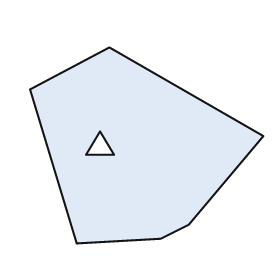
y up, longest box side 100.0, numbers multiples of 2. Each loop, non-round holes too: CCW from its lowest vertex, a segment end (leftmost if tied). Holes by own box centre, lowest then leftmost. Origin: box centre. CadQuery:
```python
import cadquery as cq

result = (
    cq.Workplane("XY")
    .moveTo(-30.0, -42.0)
    .lineTo(6.0, -40.0)
    .lineTo(18.0, -34.0)
    .lineTo(50.0, 4.0)
    .lineTo(-16.0, 42.0)
    .lineTo(-50.0, 24.0)
    .close()
    .moveTo(-26.0, -4.0)
    .lineTo(-14.0, -4.0)
    .lineTo(-20.0, 6.0)
    .close()
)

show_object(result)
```